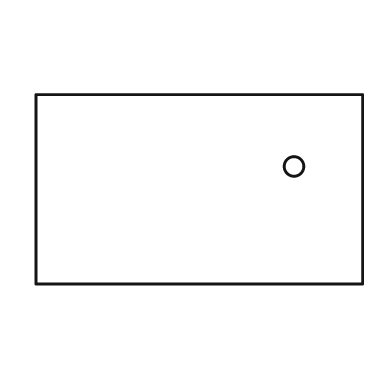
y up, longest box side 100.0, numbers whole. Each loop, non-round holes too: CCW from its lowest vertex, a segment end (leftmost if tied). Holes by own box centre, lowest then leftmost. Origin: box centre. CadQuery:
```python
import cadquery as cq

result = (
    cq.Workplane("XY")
    .moveTo(-50.0, -29.0)
    .lineTo(50.0, -29.0)
    .lineTo(50.0, 29.0)
    .lineTo(-50.0, 29.0)
    .close()
    .moveTo(29.0, 7.0)
    .circle(3.0)
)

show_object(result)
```